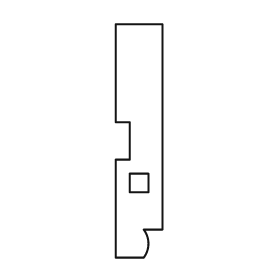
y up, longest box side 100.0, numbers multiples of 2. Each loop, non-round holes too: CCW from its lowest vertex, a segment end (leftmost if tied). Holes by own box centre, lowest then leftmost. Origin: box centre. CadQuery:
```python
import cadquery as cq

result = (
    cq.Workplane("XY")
    .moveTo(-10.0, -50.0)
    .lineTo(2.0, -50.0)
    .threePointArc((4.0, -44.0), (2.0, -38.0))
    .lineTo(10.0, -38.0)
    .lineTo(10.0, 50.0)
    .lineTo(-10.0, 50.0)
    .lineTo(-10.0, 8.0)
    .lineTo(-4.0, 8.0)
    .lineTo(-4.0, -8.0)
    .lineTo(-10.0, -8.0)
    .close()
    .moveTo(-4.0, -22.0)
    .lineTo(4.0, -22.0)
    .lineTo(4.0, -14.0)
    .lineTo(-4.0, -14.0)
    .close()
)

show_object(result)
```